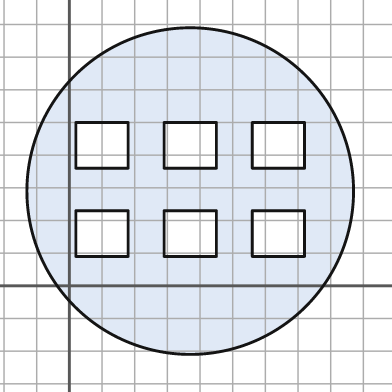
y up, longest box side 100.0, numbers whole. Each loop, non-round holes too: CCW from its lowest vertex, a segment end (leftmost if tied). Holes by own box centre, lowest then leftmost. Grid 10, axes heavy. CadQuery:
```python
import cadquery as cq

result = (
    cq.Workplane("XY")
    .moveTo(37.0, 29.0)
    .circle(50.0)
    .moveTo(2.0, 9.0)
    .lineTo(18.0, 9.0)
    .lineTo(18.0, 23.0)
    .lineTo(2.0, 23.0)
    .close()
    .moveTo(29.0, 9.0)
    .lineTo(45.0, 9.0)
    .lineTo(45.0, 23.0)
    .lineTo(29.0, 23.0)
    .close()
    .moveTo(56.0, 9.0)
    .lineTo(72.0, 9.0)
    .lineTo(72.0, 23.0)
    .lineTo(56.0, 23.0)
    .close()
    .moveTo(2.0, 36.0)
    .lineTo(18.0, 36.0)
    .lineTo(18.0, 50.0)
    .lineTo(2.0, 50.0)
    .close()
    .moveTo(29.0, 36.0)
    .lineTo(45.0, 36.0)
    .lineTo(45.0, 50.0)
    .lineTo(29.0, 50.0)
    .close()
    .moveTo(56.0, 36.0)
    .lineTo(72.0, 36.0)
    .lineTo(72.0, 50.0)
    .lineTo(56.0, 50.0)
    .close()
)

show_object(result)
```